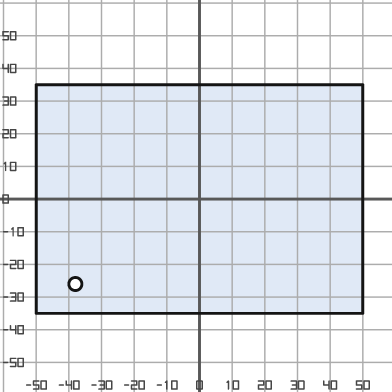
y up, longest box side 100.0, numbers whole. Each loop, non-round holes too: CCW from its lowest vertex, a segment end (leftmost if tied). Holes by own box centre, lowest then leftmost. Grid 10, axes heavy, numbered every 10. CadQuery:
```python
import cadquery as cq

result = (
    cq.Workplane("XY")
    .moveTo(-50.0, -35.0)
    .lineTo(50.0, -35.0)
    .lineTo(50.0, 35.0)
    .lineTo(-50.0, 35.0)
    .close()
    .moveTo(-38.0, -26.0)
    .circle(2.0)
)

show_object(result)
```